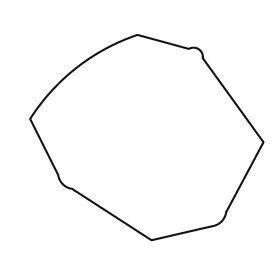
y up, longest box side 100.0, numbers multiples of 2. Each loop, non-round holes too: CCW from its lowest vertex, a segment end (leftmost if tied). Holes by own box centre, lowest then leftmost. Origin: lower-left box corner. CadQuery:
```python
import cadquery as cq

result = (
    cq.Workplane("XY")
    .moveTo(52.0, 0.0)
    .lineTo(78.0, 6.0)
    .threePointArc((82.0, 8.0), (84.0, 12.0))
    .lineTo(100.0, 42.0)
    .lineTo(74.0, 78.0)
    .threePointArc((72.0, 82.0), (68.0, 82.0))
    .lineTo(46.0, 88.0)
    .threePointArc((20.0, 74.0), (0.0, 52.0))
    .lineTo(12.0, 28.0)
    .threePointArc((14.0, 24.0), (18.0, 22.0))
    .close()
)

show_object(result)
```